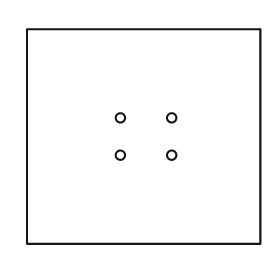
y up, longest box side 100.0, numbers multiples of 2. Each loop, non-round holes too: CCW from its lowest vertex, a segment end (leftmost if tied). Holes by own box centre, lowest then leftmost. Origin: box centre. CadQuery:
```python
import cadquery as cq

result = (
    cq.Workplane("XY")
    .moveTo(-50.0, -46.0)
    .lineTo(50.0, -46.0)
    .lineTo(50.0, 46.0)
    .lineTo(-50.0, 46.0)
    .close()
    .moveTo(-10.0, -8.0)
    .circle(2.0)
    .moveTo(12.0, -8.0)
    .circle(2.0)
    .moveTo(-10.0, 8.0)
    .circle(2.0)
    .moveTo(12.0, 8.0)
    .circle(2.0)
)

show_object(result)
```